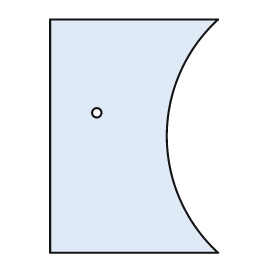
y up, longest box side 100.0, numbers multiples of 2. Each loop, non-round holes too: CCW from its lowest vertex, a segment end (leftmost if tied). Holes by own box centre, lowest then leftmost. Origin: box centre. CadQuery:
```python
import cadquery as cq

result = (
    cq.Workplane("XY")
    .moveTo(-36.0, -50.0)
    .lineTo(36.0, -50.0)
    .threePointArc((14.0, 0.0), (36.0, 50.0))
    .lineTo(-36.0, 50.0)
    .close()
    .moveTo(-16.0, 10.0)
    .circle(2.0)
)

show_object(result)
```